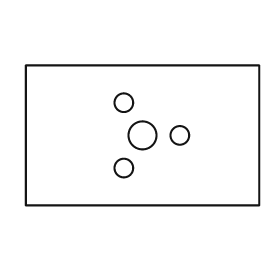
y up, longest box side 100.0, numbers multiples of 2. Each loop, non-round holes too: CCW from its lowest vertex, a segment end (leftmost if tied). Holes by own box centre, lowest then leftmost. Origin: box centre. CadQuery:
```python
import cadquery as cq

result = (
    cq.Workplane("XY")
    .moveTo(-50.0, -30.0)
    .lineTo(50.0, -30.0)
    .lineTo(50.0, 30.0)
    .lineTo(-50.0, 30.0)
    .close()
    .moveTo(-8.0, -14.0)
    .circle(4.0)
    .moveTo(0.0, 0.0)
    .circle(6.0)
    .moveTo(16.0, 0.0)
    .circle(4.0)
    .moveTo(-8.0, 14.0)
    .circle(4.0)
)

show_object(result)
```